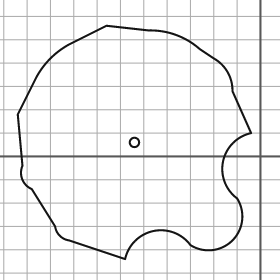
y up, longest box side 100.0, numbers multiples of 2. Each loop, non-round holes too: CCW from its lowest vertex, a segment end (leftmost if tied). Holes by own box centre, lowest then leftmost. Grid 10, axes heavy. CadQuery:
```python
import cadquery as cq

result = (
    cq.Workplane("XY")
    .moveTo(-58.0, -44.0)
    .threePointArc((-46.0, -32.0), (-30.0, -38.0))
    .threePointArc((-12.0, -36.0), (-10.0, -18.0))
    .threePointArc((-16.0, -2.0), (-4.0, 10.0))
    .lineTo(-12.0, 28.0)
    .threePointArc((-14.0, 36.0), (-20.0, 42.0))
    .lineTo(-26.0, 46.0)
    .threePointArc((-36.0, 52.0), (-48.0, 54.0))
    .lineTo(-66.0, 56.0)
    .lineTo(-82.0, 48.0)
    .threePointArc((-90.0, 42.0), (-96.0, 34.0))
    .lineTo(-104.0, 18.0)
    .lineTo(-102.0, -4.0)
    .threePointArc((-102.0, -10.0), (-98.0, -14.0))
    .lineTo(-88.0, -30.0)
    .threePointArc((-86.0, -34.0), (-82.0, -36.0))
    .close()
    .moveTo(-54.0, 6.0)
    .circle(2.0)
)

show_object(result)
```